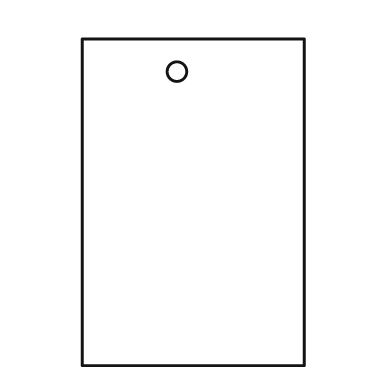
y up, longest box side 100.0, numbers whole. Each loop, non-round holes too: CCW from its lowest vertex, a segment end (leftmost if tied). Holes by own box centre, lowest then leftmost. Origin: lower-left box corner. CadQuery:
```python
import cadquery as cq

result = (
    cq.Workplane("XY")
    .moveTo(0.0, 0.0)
    .lineTo(68.0, 0.0)
    .lineTo(68.0, 100.0)
    .lineTo(0.0, 100.0)
    .close()
    .moveTo(29.0, 90.0)
    .circle(3.0)
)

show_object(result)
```